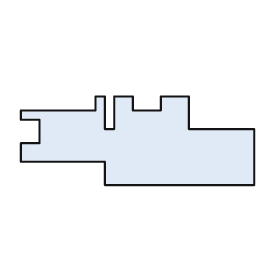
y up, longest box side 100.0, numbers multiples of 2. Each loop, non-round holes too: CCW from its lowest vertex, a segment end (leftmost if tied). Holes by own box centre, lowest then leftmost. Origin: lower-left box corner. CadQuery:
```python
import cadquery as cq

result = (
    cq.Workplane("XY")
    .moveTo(36.0, 0.0)
    .lineTo(100.0, 0.0)
    .lineTo(100.0, 24.0)
    .lineTo(72.0, 24.0)
    .lineTo(72.0, 38.0)
    .lineTo(60.0, 38.0)
    .lineTo(60.0, 32.0)
    .lineTo(48.0, 32.0)
    .lineTo(48.0, 38.0)
    .lineTo(40.0, 38.0)
    .lineTo(40.0, 24.0)
    .lineTo(36.0, 24.0)
    .lineTo(36.0, 38.0)
    .lineTo(32.0, 38.0)
    .lineTo(32.0, 32.0)
    .lineTo(0.0, 32.0)
    .lineTo(0.0, 28.0)
    .lineTo(8.0, 28.0)
    .lineTo(8.0, 18.0)
    .lineTo(0.0, 18.0)
    .lineTo(0.0, 10.0)
    .lineTo(36.0, 10.0)
    .close()
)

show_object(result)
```